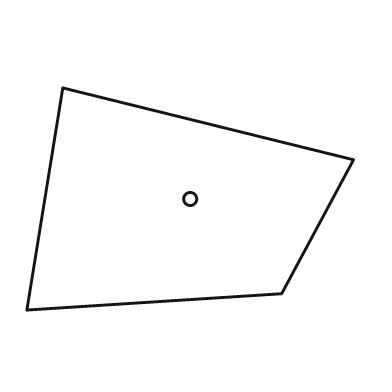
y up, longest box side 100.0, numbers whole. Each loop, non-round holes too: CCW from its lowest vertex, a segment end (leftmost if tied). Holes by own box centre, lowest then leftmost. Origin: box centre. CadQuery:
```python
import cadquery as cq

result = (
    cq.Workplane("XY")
    .moveTo(-50.0, -34.0)
    .lineTo(28.0, -29.0)
    .lineTo(50.0, 12.0)
    .lineTo(-39.0, 34.0)
    .close()
    .moveTo(0.0, 0.0)
    .circle(2.0)
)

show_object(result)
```